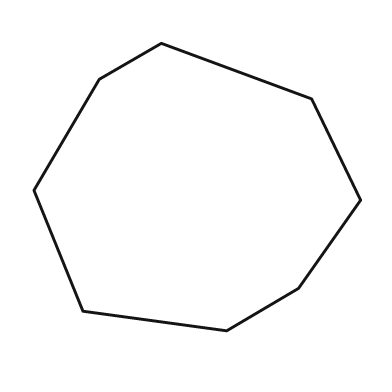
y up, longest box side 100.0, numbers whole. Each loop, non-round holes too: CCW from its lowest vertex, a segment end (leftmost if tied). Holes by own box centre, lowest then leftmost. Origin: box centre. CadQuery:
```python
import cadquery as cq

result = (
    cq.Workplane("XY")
    .moveTo(9.0, -44.0)
    .lineTo(31.0, -31.0)
    .lineTo(50.0, -4.0)
    .lineTo(35.0, 27.0)
    .lineTo(-11.0, 44.0)
    .lineTo(-30.0, 33.0)
    .lineTo(-50.0, -1.0)
    .lineTo(-35.0, -38.0)
    .close()
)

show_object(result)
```